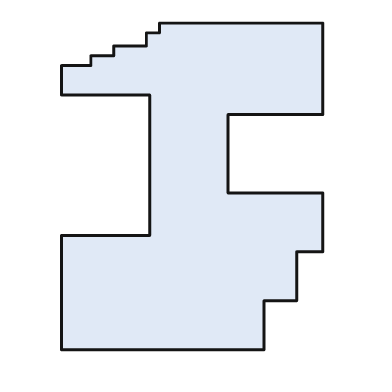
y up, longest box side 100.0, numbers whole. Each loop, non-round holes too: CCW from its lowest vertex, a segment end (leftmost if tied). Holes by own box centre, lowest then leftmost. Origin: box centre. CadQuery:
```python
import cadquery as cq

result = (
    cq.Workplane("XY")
    .moveTo(-40.0, -50.0)
    .lineTo(22.0, -50.0)
    .lineTo(22.0, -35.0)
    .lineTo(32.0, -35.0)
    .lineTo(32.0, -20.0)
    .lineTo(40.0, -20.0)
    .lineTo(40.0, -2.0)
    .lineTo(11.0, -2.0)
    .lineTo(11.0, 22.0)
    .lineTo(40.0, 22.0)
    .lineTo(40.0, 50.0)
    .lineTo(-10.0, 50.0)
    .lineTo(-10.0, 47.0)
    .lineTo(-14.0, 47.0)
    .lineTo(-14.0, 43.0)
    .lineTo(-24.0, 43.0)
    .lineTo(-24.0, 40.0)
    .lineTo(-31.0, 40.0)
    .lineTo(-31.0, 37.0)
    .lineTo(-40.0, 37.0)
    .lineTo(-40.0, 28.0)
    .lineTo(-13.0, 28.0)
    .lineTo(-13.0, -15.0)
    .lineTo(-40.0, -15.0)
    .close()
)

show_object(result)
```